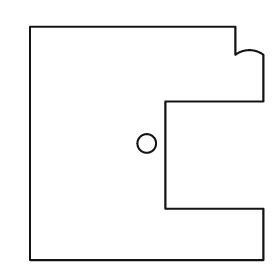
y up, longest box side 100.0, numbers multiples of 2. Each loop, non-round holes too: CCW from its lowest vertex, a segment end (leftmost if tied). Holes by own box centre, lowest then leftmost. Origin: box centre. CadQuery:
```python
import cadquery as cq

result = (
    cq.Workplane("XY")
    .moveTo(-50.0, -50.0)
    .lineTo(50.0, -50.0)
    .lineTo(50.0, -28.0)
    .lineTo(8.0, -28.0)
    .lineTo(8.0, 18.0)
    .lineTo(50.0, 18.0)
    .lineTo(50.0, 38.0)
    .threePointArc((44.0, 40.0), (38.0, 38.0))
    .lineTo(38.0, 50.0)
    .lineTo(-50.0, 50.0)
    .close()
    .moveTo(0.0, 0.0)
    .circle(4.0)
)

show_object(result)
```